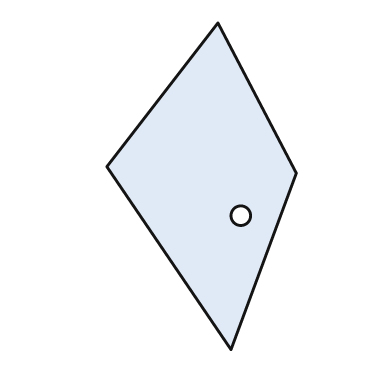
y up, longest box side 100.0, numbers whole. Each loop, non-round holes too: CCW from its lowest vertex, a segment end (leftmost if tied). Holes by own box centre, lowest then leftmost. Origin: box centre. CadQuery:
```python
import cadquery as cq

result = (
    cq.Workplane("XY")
    .moveTo(9.0, -50.0)
    .lineTo(29.0, 4.0)
    .lineTo(5.0, 50.0)
    .lineTo(-29.0, 6.0)
    .close()
    .moveTo(12.0, -9.0)
    .circle(3.0)
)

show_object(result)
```